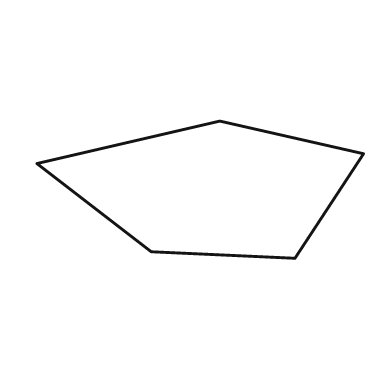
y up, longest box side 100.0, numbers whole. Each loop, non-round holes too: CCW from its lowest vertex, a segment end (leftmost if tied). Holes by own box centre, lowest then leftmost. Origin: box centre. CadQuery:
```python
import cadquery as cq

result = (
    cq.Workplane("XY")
    .moveTo(29.0, -21.0)
    .lineTo(50.0, 11.0)
    .lineTo(6.0, 21.0)
    .lineTo(-50.0, 8.0)
    .lineTo(-15.0, -19.0)
    .close()
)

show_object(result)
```